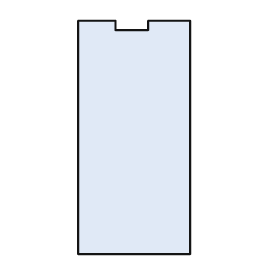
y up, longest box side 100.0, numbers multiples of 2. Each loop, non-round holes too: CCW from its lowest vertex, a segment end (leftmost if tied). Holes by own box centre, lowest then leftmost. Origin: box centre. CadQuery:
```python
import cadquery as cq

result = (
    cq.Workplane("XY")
    .moveTo(-24.0, -50.0)
    .lineTo(24.0, -50.0)
    .lineTo(24.0, 50.0)
    .lineTo(6.0, 50.0)
    .lineTo(6.0, 46.0)
    .lineTo(-8.0, 46.0)
    .lineTo(-8.0, 50.0)
    .lineTo(-24.0, 50.0)
    .close()
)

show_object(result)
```